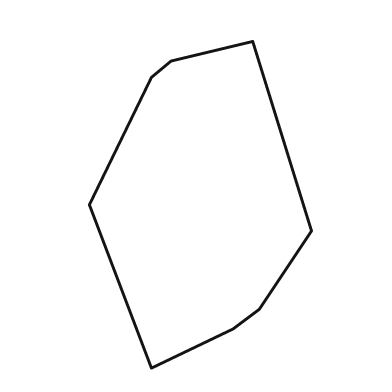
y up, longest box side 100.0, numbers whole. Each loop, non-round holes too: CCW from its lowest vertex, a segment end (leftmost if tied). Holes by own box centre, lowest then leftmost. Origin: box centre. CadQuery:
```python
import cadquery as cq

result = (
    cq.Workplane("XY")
    .moveTo(-15.0, -50.0)
    .lineTo(10.0, -38.0)
    .lineTo(18.0, -32.0)
    .lineTo(34.0, -8.0)
    .lineTo(16.0, 50.0)
    .lineTo(-9.0, 44.0)
    .lineTo(-15.0, 39.0)
    .lineTo(-34.0, 0.0)
    .close()
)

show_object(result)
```